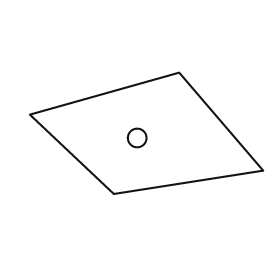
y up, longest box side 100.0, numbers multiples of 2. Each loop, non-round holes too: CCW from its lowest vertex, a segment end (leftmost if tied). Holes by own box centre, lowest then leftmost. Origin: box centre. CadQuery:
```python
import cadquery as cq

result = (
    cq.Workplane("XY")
    .moveTo(-14.0, -26.0)
    .lineTo(50.0, -16.0)
    .lineTo(14.0, 26.0)
    .lineTo(-50.0, 8.0)
    .close()
    .moveTo(-4.0, -2.0)
    .circle(4.0)
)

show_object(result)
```